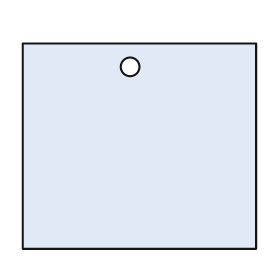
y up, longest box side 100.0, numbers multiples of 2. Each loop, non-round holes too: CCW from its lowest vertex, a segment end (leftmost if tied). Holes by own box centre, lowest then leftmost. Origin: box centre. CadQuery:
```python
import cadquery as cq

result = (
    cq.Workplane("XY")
    .moveTo(-50.0, -44.0)
    .lineTo(50.0, -44.0)
    .lineTo(50.0, 44.0)
    .lineTo(-50.0, 44.0)
    .close()
    .moveTo(-4.0, 34.0)
    .circle(4.0)
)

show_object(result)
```